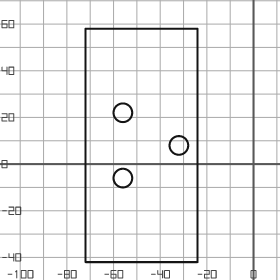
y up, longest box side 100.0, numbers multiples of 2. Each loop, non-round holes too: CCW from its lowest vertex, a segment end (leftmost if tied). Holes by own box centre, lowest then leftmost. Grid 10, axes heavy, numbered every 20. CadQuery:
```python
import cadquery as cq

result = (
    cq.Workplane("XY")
    .moveTo(-72.0, -42.0)
    .lineTo(-24.0, -42.0)
    .lineTo(-24.0, 58.0)
    .lineTo(-72.0, 58.0)
    .close()
    .moveTo(-56.0, -6.0)
    .circle(4.0)
    .moveTo(-32.0, 8.0)
    .circle(4.0)
    .moveTo(-56.0, 22.0)
    .circle(4.0)
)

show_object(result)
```